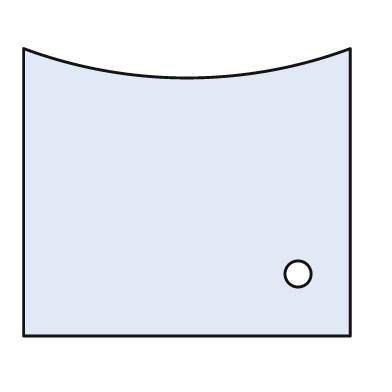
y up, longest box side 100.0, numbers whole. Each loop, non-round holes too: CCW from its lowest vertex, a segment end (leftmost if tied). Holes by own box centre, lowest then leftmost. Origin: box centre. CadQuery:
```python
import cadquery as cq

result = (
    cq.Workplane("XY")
    .moveTo(-50.0, -44.0)
    .lineTo(50.0, -44.0)
    .lineTo(50.0, 44.0)
    .threePointArc((0.0, 35.0), (-50.0, 44.0))
    .close()
    .moveTo(34.0, -25.0)
    .circle(4.0)
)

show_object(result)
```